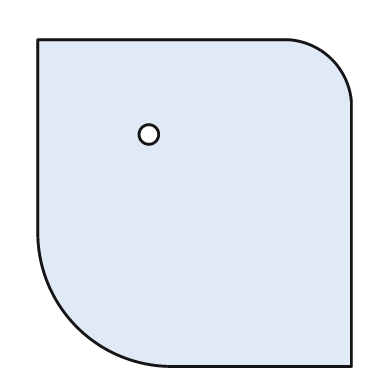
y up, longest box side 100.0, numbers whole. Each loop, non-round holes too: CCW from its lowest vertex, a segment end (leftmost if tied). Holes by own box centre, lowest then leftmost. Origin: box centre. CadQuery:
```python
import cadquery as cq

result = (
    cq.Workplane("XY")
    .moveTo(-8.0, -50.0)
    .lineTo(48.0, -50.0)
    .lineTo(48.0, 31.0)
    .threePointArc((42.0, 44.0), (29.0, 50.0))
    .lineTo(-48.0, 50.0)
    .lineTo(-48.0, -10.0)
    .threePointArc((-36.0, -38.0), (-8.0, -50.0))
    .close()
    .moveTo(-14.0, 21.0)
    .circle(3.0)
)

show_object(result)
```